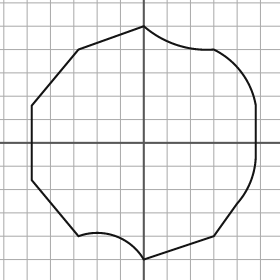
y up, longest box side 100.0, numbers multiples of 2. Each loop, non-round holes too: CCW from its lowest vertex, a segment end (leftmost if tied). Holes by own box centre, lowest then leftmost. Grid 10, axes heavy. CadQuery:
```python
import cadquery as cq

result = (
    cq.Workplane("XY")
    .moveTo(0.0, -50.0)
    .lineTo(30.0, -40.0)
    .lineTo(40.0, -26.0)
    .threePointArc((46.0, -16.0), (48.0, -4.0))
    .lineTo(48.0, 16.0)
    .threePointArc((42.0, 30.0), (30.0, 40.0))
    .threePointArc((14.0, 42.0), (0.0, 50.0))
    .lineTo(-28.0, 40.0)
    .lineTo(-48.0, 16.0)
    .lineTo(-48.0, -16.0)
    .lineTo(-28.0, -40.0)
    .threePointArc((-12.0, -40.0), (0.0, -50.0))
    .close()
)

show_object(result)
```